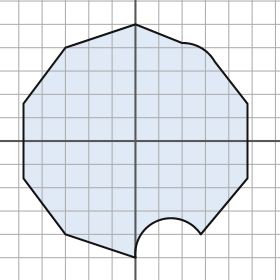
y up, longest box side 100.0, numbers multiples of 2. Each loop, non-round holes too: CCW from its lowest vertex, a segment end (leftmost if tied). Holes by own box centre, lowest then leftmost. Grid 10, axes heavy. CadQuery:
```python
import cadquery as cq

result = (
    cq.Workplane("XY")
    .moveTo(0.0, -50.0)
    .threePointArc((10.0, -34.0), (28.0, -40.0))
    .lineTo(48.0, -16.0)
    .lineTo(48.0, 16.0)
    .lineTo(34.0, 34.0)
    .threePointArc((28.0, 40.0), (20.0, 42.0))
    .lineTo(0.0, 50.0)
    .lineTo(-30.0, 40.0)
    .lineTo(-48.0, 16.0)
    .lineTo(-48.0, -16.0)
    .lineTo(-30.0, -40.0)
    .close()
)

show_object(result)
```